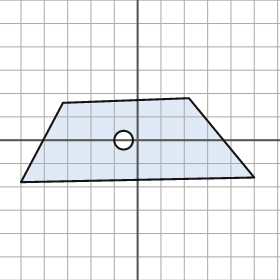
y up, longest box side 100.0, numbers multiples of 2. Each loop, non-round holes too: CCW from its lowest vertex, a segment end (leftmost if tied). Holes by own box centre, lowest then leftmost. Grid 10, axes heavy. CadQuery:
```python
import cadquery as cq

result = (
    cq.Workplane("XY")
    .moveTo(-50.0, -18.0)
    .lineTo(50.0, -16.0)
    .lineTo(22.0, 18.0)
    .lineTo(-32.0, 16.0)
    .close()
    .moveTo(-6.0, 0.0)
    .circle(4.0)
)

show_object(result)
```